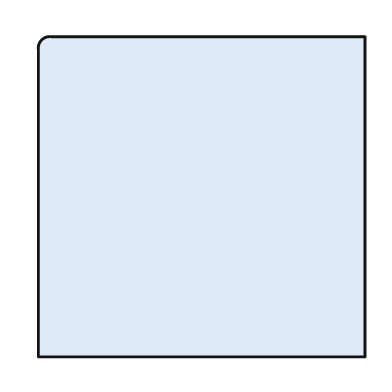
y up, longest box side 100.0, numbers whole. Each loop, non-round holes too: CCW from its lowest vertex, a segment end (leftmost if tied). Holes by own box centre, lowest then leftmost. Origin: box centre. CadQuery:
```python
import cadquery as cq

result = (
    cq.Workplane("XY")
    .moveTo(-50.0, -49.0)
    .lineTo(50.0, -49.0)
    .lineTo(50.0, 49.0)
    .lineTo(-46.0, 49.0)
    .threePointArc((-49.0, 48.0), (-50.0, 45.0))
    .close()
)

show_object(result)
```